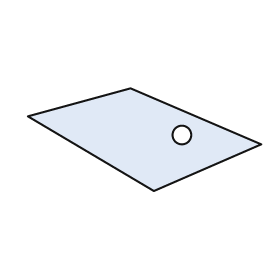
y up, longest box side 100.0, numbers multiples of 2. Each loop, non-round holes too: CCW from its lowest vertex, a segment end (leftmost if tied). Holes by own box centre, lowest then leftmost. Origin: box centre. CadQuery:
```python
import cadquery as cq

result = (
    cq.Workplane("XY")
    .moveTo(4.0, -22.0)
    .lineTo(50.0, -2.0)
    .lineTo(-6.0, 22.0)
    .lineTo(-50.0, 10.0)
    .close()
    .moveTo(16.0, 2.0)
    .circle(4.0)
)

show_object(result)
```